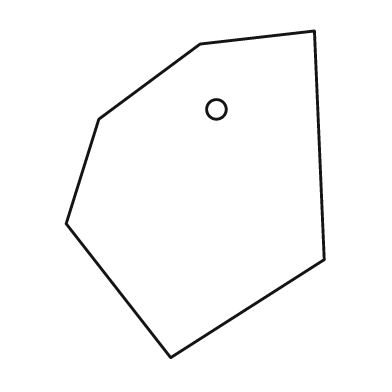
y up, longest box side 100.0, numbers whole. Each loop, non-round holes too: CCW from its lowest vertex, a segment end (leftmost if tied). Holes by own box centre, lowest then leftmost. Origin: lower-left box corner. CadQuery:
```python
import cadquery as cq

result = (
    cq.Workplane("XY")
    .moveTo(32.0, 0.0)
    .lineTo(79.0, 30.0)
    .lineTo(76.0, 100.0)
    .lineTo(41.0, 96.0)
    .lineTo(10.0, 73.0)
    .lineTo(0.0, 41.0)
    .close()
    .moveTo(46.0, 76.0)
    .circle(3.0)
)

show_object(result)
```